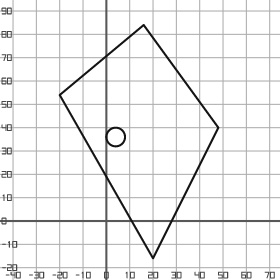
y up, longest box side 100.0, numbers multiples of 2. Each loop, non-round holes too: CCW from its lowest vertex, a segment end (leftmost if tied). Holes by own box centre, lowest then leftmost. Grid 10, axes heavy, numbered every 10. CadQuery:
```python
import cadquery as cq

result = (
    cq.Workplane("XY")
    .moveTo(20.0, -16.0)
    .lineTo(48.0, 40.0)
    .lineTo(16.0, 84.0)
    .lineTo(-20.0, 54.0)
    .close()
    .moveTo(4.0, 36.0)
    .circle(4.0)
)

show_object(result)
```